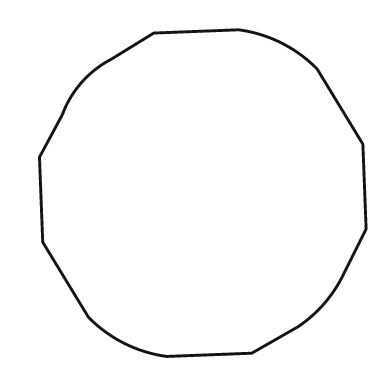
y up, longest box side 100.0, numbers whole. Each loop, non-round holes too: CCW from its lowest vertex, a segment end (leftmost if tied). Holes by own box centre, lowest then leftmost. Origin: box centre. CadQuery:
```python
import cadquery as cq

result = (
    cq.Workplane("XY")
    .moveTo(-11.0, -50.0)
    .lineTo(15.0, -49.0)
    .lineTo(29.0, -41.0)
    .threePointArc((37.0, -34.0), (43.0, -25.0))
    .lineTo(50.0, -11.0)
    .lineTo(49.0, 15.0)
    .lineTo(35.0, 38.0)
    .threePointArc((24.0, 46.0), (11.0, 50.0))
    .lineTo(-15.0, 49.0)
    .lineTo(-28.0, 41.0)
    .threePointArc((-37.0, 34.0), (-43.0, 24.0))
    .lineTo(-50.0, 11.0)
    .lineTo(-49.0, -15.0)
    .lineTo(-35.0, -38.0)
    .threePointArc((-24.0, -46.0), (-11.0, -50.0))
    .close()
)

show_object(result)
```